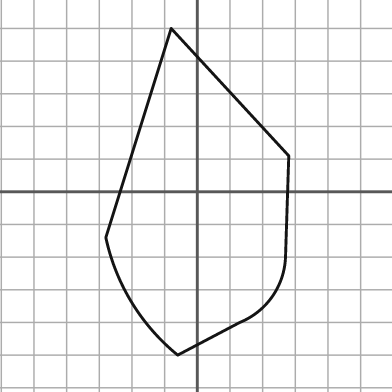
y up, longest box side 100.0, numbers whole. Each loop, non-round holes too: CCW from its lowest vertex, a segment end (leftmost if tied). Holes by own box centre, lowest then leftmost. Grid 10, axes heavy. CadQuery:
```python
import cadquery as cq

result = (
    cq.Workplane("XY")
    .moveTo(-6.0, -50.0)
    .lineTo(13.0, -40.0)
    .threePointArc((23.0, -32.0), (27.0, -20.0))
    .lineTo(28.0, 11.0)
    .lineTo(-8.0, 50.0)
    .lineTo(-28.0, -14.0)
    .threePointArc((-20.0, -34.0), (-6.0, -50.0))
    .close()
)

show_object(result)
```